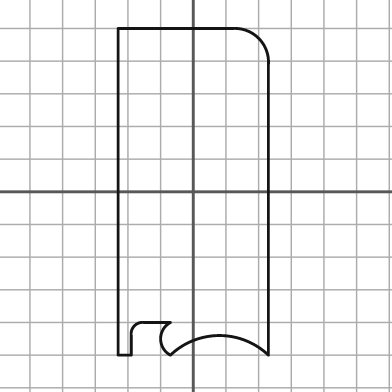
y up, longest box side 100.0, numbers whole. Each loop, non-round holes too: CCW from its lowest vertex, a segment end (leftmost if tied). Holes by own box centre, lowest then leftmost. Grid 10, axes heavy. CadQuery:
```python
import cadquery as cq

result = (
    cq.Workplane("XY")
    .moveTo(-23.0, -50.0)
    .lineTo(-19.0, -50.0)
    .lineTo(-19.0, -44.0)
    .threePointArc((-18.0, -41.0), (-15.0, -40.0))
    .lineTo(-7.0, -40.0)
    .threePointArc((-10.0, -45.0), (-7.0, -50.0))
    .threePointArc((8.0, -44.0), (23.0, -50.0))
    .lineTo(23.0, 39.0)
    .threePointArc((20.0, 47.0), (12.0, 50.0))
    .lineTo(-23.0, 50.0)
    .close()
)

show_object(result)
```